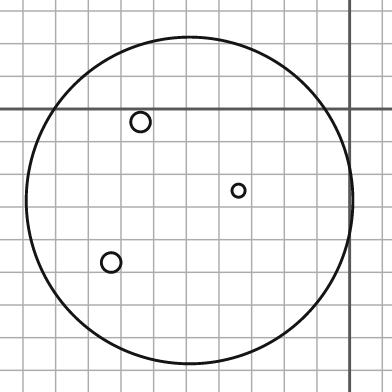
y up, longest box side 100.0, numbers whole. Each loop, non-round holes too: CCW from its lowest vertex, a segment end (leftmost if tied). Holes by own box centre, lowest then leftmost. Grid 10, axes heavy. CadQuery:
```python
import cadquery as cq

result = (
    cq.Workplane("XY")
    .moveTo(-49.0, -28.0)
    .circle(50.0)
    .moveTo(-73.0, -47.0)
    .circle(3.0)
    .moveTo(-34.0, -25.0)
    .circle(2.0)
    .moveTo(-64.0, -4.0)
    .circle(3.0)
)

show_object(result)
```